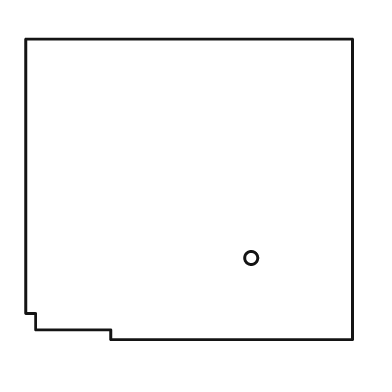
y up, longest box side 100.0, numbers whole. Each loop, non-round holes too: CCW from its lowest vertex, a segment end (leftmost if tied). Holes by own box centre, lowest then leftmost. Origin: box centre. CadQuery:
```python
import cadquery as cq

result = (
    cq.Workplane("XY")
    .moveTo(-24.0, -46.0)
    .lineTo(50.0, -46.0)
    .lineTo(50.0, 46.0)
    .lineTo(-50.0, 46.0)
    .lineTo(-50.0, -38.0)
    .lineTo(-47.0, -38.0)
    .lineTo(-47.0, -43.0)
    .lineTo(-24.0, -43.0)
    .close()
    .moveTo(19.0, -21.0)
    .circle(2.0)
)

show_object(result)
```